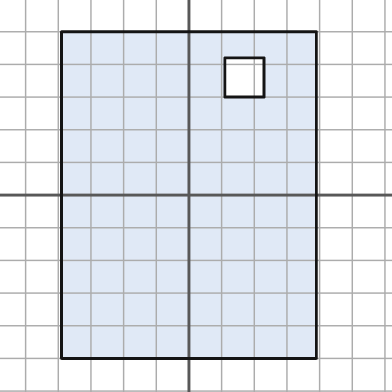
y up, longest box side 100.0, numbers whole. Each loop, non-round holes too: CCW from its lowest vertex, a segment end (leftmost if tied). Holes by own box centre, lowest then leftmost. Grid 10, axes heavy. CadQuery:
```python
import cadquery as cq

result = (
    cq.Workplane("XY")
    .moveTo(-39.0, -50.0)
    .lineTo(39.0, -50.0)
    .lineTo(39.0, 50.0)
    .lineTo(-39.0, 50.0)
    .close()
    .moveTo(11.0, 30.0)
    .lineTo(23.0, 30.0)
    .lineTo(23.0, 42.0)
    .lineTo(11.0, 42.0)
    .close()
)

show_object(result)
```